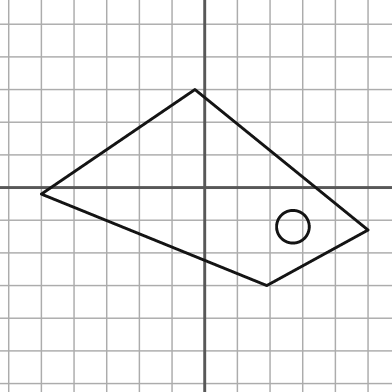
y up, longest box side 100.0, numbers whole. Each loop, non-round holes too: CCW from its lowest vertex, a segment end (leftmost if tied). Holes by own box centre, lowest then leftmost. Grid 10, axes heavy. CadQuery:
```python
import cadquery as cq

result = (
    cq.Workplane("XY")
    .moveTo(19.0, -30.0)
    .lineTo(50.0, -13.0)
    .lineTo(-3.0, 30.0)
    .lineTo(-50.0, -2.0)
    .close()
    .moveTo(27.0, -12.0)
    .circle(5.0)
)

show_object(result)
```